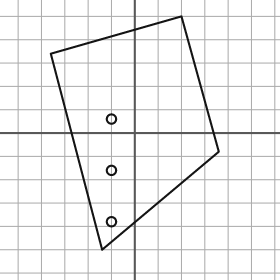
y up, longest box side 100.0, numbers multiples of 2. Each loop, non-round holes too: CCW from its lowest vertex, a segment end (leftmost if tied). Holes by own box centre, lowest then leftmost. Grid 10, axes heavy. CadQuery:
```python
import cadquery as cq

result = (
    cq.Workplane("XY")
    .moveTo(-14.0, -50.0)
    .lineTo(36.0, -8.0)
    .lineTo(20.0, 50.0)
    .lineTo(-36.0, 34.0)
    .close()
    .moveTo(-10.0, -38.0)
    .circle(2.0)
    .moveTo(-10.0, -16.0)
    .circle(2.0)
    .moveTo(-10.0, 6.0)
    .circle(2.0)
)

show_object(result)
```